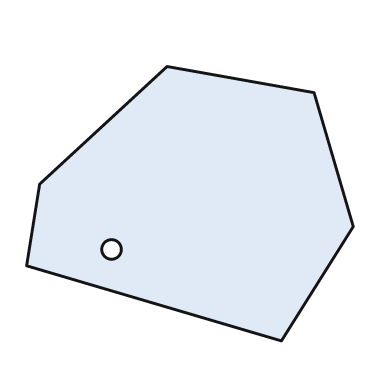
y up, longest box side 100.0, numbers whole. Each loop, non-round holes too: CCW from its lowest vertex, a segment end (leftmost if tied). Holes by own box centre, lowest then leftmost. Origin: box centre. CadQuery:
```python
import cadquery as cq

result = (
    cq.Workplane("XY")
    .moveTo(28.0, -42.0)
    .lineTo(50.0, -7.0)
    .lineTo(38.0, 34.0)
    .lineTo(-7.0, 42.0)
    .lineTo(-46.0, 6.0)
    .lineTo(-50.0, -19.0)
    .close()
    .moveTo(-24.0, -14.0)
    .circle(3.0)
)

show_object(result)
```